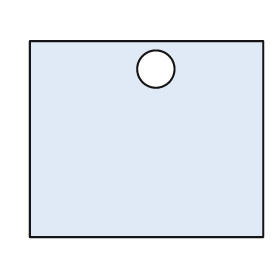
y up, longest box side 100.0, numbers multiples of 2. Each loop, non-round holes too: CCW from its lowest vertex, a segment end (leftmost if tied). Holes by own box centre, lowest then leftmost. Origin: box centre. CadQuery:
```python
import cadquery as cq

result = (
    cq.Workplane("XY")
    .moveTo(-50.0, -42.0)
    .lineTo(50.0, -42.0)
    .lineTo(50.0, 42.0)
    .lineTo(-50.0, 42.0)
    .close()
    .moveTo(4.0, 30.0)
    .circle(8.0)
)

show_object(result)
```